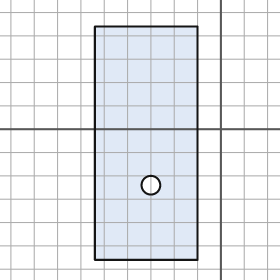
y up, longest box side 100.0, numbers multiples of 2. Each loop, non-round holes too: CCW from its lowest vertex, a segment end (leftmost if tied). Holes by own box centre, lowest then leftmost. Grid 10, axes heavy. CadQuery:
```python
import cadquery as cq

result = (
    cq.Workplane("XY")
    .moveTo(-54.0, -56.0)
    .lineTo(-10.0, -56.0)
    .lineTo(-10.0, 44.0)
    .lineTo(-54.0, 44.0)
    .close()
    .moveTo(-30.0, -24.0)
    .circle(4.0)
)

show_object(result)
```